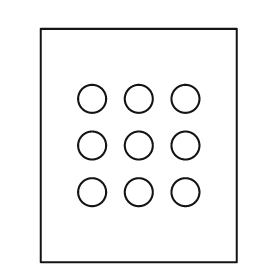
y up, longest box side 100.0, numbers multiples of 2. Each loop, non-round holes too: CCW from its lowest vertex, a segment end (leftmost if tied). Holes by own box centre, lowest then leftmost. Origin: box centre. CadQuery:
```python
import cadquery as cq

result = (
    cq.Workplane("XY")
    .moveTo(-42.0, -50.0)
    .lineTo(42.0, -50.0)
    .lineTo(42.0, 50.0)
    .lineTo(-42.0, 50.0)
    .close()
    .moveTo(-20.0, -20.0)
    .circle(6.0)
    .moveTo(0.0, -20.0)
    .circle(6.0)
    .moveTo(20.0, -20.0)
    .circle(6.0)
    .moveTo(-20.0, 0.0)
    .circle(6.0)
    .moveTo(0.0, 0.0)
    .circle(6.0)
    .moveTo(20.0, 0.0)
    .circle(6.0)
    .moveTo(-20.0, 20.0)
    .circle(6.0)
    .moveTo(0.0, 20.0)
    .circle(6.0)
    .moveTo(20.0, 20.0)
    .circle(6.0)
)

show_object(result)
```